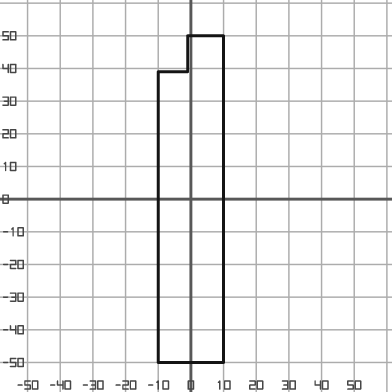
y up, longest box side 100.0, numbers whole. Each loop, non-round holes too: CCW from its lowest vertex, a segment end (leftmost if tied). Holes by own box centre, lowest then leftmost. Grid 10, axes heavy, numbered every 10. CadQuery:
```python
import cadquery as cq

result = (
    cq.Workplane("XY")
    .moveTo(-10.0, -50.0)
    .lineTo(10.0, -50.0)
    .lineTo(10.0, 50.0)
    .lineTo(-1.0, 50.0)
    .lineTo(-1.0, 39.0)
    .lineTo(-10.0, 39.0)
    .close()
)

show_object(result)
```